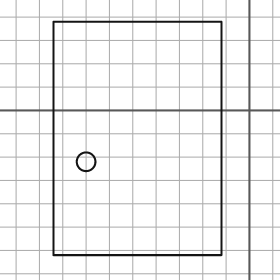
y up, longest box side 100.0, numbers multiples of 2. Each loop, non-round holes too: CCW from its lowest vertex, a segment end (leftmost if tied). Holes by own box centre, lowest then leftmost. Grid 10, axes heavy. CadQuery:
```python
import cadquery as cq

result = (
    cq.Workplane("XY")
    .moveTo(-84.0, -62.0)
    .lineTo(-12.0, -62.0)
    .lineTo(-12.0, 38.0)
    .lineTo(-84.0, 38.0)
    .close()
    .moveTo(-70.0, -22.0)
    .circle(4.0)
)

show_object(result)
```